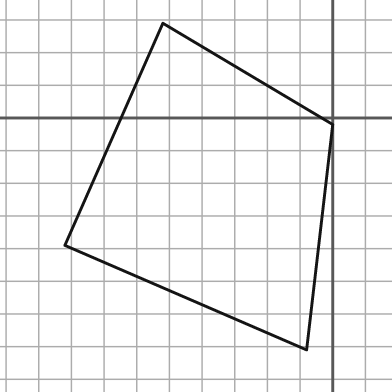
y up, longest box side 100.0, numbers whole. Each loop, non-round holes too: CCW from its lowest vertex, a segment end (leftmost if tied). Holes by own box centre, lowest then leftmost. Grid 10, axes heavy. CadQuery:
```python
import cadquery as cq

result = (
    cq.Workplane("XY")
    .moveTo(-8.0, -71.0)
    .lineTo(0.0, -2.0)
    .lineTo(-52.0, 29.0)
    .lineTo(-82.0, -39.0)
    .close()
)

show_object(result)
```